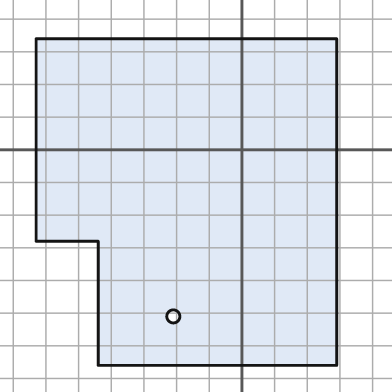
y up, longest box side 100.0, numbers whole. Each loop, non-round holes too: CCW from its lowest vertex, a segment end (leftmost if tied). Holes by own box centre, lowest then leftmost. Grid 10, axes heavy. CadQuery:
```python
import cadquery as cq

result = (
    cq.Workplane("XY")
    .moveTo(-44.0, -66.0)
    .lineTo(29.0, -66.0)
    .lineTo(29.0, 34.0)
    .lineTo(-63.0, 34.0)
    .lineTo(-63.0, -28.0)
    .lineTo(-44.0, -28.0)
    .close()
    .moveTo(-21.0, -51.0)
    .circle(2.0)
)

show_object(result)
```